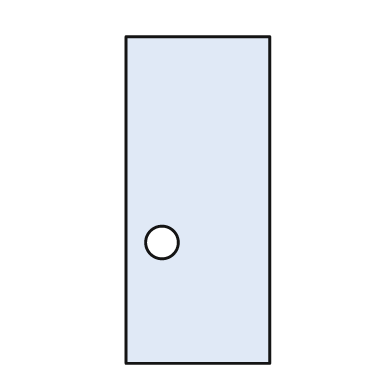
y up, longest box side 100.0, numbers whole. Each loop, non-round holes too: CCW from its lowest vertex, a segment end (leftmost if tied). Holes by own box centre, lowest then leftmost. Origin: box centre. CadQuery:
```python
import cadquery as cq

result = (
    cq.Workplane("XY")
    .moveTo(-22.0, -50.0)
    .lineTo(22.0, -50.0)
    .lineTo(22.0, 50.0)
    .lineTo(-22.0, 50.0)
    .close()
    .moveTo(-11.0, -13.0)
    .circle(5.0)
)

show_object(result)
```